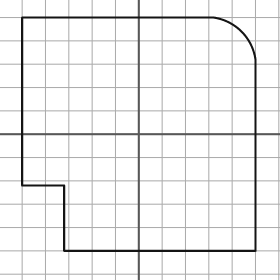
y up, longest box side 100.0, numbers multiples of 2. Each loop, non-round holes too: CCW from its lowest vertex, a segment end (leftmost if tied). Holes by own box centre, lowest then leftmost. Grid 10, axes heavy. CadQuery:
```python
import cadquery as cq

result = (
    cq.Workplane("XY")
    .moveTo(-32.0, -50.0)
    .lineTo(50.0, -50.0)
    .lineTo(50.0, 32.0)
    .threePointArc((44.0, 44.0), (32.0, 50.0))
    .lineTo(-50.0, 50.0)
    .lineTo(-50.0, -22.0)
    .lineTo(-32.0, -22.0)
    .close()
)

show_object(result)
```